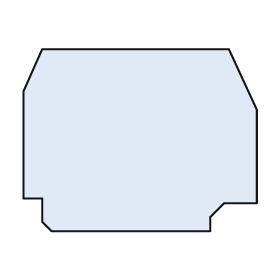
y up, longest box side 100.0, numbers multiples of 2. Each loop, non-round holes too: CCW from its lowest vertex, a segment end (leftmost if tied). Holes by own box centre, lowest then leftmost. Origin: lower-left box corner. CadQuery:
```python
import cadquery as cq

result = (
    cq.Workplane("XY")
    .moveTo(12.0, 0.0)
    .lineTo(80.0, 0.0)
    .lineTo(80.0, 6.0)
    .lineTo(86.0, 12.0)
    .lineTo(100.0, 12.0)
    .lineTo(100.0, 52.0)
    .lineTo(88.0, 78.0)
    .lineTo(8.0, 78.0)
    .lineTo(0.0, 60.0)
    .lineTo(0.0, 14.0)
    .lineTo(8.0, 14.0)
    .lineTo(8.0, 4.0)
    .close()
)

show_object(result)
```